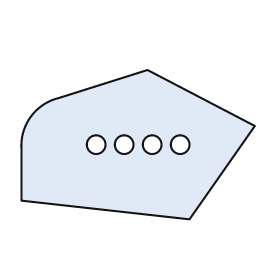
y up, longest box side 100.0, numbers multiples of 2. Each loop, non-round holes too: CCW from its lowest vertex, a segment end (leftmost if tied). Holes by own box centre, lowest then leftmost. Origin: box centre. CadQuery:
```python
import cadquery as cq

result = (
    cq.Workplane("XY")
    .moveTo(22.0, -32.0)
    .lineTo(50.0, 8.0)
    .lineTo(4.0, 32.0)
    .lineTo(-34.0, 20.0)
    .threePointArc((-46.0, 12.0), (-50.0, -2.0))
    .lineTo(-50.0, -24.0)
    .close()
    .moveTo(-18.0, 0.0)
    .circle(4.0)
    .moveTo(-6.0, 0.0)
    .circle(4.0)
    .moveTo(6.0, 0.0)
    .circle(4.0)
    .moveTo(18.0, 0.0)
    .circle(4.0)
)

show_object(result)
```